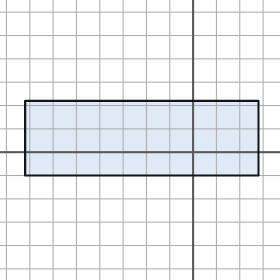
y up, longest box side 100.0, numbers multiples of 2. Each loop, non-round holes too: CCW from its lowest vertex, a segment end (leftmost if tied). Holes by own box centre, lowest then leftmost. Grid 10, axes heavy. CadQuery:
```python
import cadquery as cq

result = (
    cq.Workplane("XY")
    .moveTo(-72.0, -10.0)
    .lineTo(28.0, -10.0)
    .lineTo(28.0, 22.0)
    .lineTo(-72.0, 22.0)
    .close()
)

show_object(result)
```